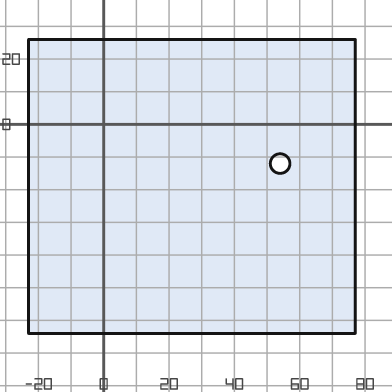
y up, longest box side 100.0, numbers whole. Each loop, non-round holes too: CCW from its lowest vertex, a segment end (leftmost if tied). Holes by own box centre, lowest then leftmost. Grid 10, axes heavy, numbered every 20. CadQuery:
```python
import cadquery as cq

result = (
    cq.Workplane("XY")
    .moveTo(-23.0, -64.0)
    .lineTo(77.0, -64.0)
    .lineTo(77.0, 26.0)
    .lineTo(-23.0, 26.0)
    .close()
    .moveTo(54.0, -12.0)
    .circle(3.0)
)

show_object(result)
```